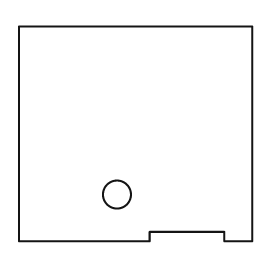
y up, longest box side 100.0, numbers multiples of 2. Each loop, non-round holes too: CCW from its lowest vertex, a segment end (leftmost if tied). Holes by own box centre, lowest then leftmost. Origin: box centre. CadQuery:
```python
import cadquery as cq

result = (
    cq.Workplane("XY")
    .moveTo(-50.0, -46.0)
    .lineTo(6.0, -46.0)
    .lineTo(6.0, -42.0)
    .lineTo(38.0, -42.0)
    .lineTo(38.0, -46.0)
    .lineTo(50.0, -46.0)
    .lineTo(50.0, 46.0)
    .lineTo(-50.0, 46.0)
    .close()
    .moveTo(-8.0, -26.0)
    .circle(6.0)
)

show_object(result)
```